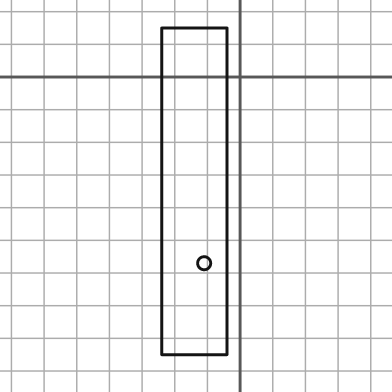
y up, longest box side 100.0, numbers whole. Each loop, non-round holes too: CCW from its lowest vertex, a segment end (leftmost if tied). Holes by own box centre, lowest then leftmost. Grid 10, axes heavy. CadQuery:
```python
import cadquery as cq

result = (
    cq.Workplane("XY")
    .moveTo(-24.0, -85.0)
    .lineTo(-4.0, -85.0)
    .lineTo(-4.0, 15.0)
    .lineTo(-24.0, 15.0)
    .close()
    .moveTo(-11.0, -57.0)
    .circle(2.0)
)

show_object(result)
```